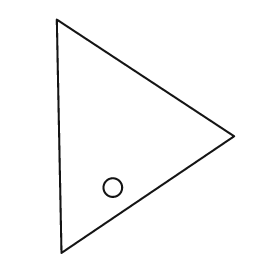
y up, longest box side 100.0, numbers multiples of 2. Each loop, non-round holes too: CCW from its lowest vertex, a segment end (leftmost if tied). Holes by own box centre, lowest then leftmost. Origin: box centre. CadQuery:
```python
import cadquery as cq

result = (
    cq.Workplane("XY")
    .moveTo(-36.0, -50.0)
    .lineTo(38.0, 0.0)
    .lineTo(-38.0, 50.0)
    .close()
    .moveTo(-14.0, -22.0)
    .circle(4.0)
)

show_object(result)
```